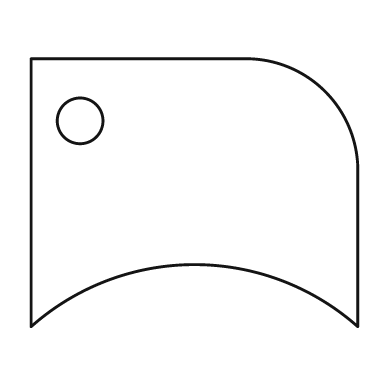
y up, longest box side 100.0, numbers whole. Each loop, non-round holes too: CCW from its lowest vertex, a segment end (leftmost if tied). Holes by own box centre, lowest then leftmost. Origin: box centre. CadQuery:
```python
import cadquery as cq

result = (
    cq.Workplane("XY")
    .moveTo(-50.0, -41.0)
    .threePointArc((0.0, -22.0), (50.0, -41.0))
    .lineTo(50.0, 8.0)
    .threePointArc((40.0, 31.0), (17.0, 41.0))
    .lineTo(-50.0, 41.0)
    .close()
    .moveTo(-35.0, 22.0)
    .circle(7.0)
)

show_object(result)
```